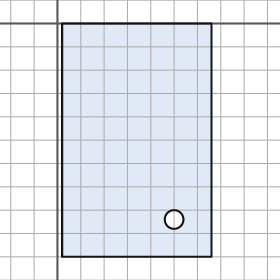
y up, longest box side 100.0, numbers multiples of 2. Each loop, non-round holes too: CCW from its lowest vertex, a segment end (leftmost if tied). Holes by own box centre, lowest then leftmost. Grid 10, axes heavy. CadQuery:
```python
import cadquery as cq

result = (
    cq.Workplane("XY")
    .moveTo(2.0, -100.0)
    .lineTo(66.0, -100.0)
    .lineTo(66.0, 0.0)
    .lineTo(2.0, 0.0)
    .close()
    .moveTo(50.0, -84.0)
    .circle(4.0)
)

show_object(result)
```